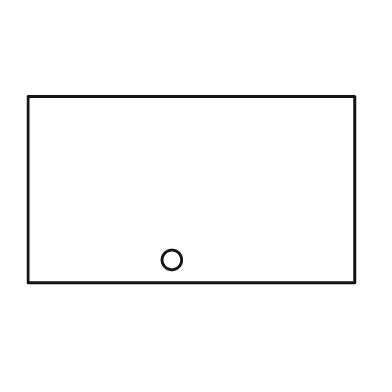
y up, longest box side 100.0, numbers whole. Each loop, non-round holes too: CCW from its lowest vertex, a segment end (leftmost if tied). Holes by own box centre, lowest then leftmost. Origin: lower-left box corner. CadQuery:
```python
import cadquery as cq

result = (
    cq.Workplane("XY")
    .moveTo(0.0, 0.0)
    .lineTo(100.0, 0.0)
    .lineTo(100.0, 57.0)
    .lineTo(0.0, 57.0)
    .close()
    .moveTo(44.0, 7.0)
    .circle(3.0)
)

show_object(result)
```